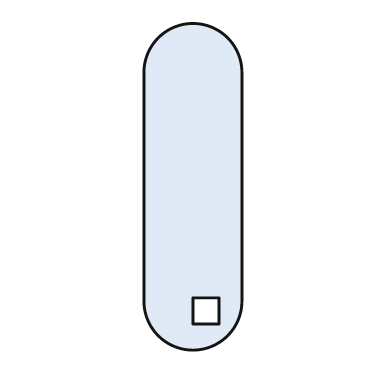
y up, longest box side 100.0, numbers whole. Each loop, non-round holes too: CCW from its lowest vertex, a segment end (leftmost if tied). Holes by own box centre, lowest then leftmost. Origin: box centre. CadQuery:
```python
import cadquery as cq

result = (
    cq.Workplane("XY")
    .moveTo(-15.0, -35.0)
    .threePointArc((0.0, -50.0), (15.0, -35.0))
    .lineTo(15.0, 35.0)
    .threePointArc((0.0, 50.0), (-15.0, 35.0))
    .close()
    .moveTo(0.0, -42.0)
    .lineTo(8.0, -42.0)
    .lineTo(8.0, -34.0)
    .lineTo(0.0, -34.0)
    .close()
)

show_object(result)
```